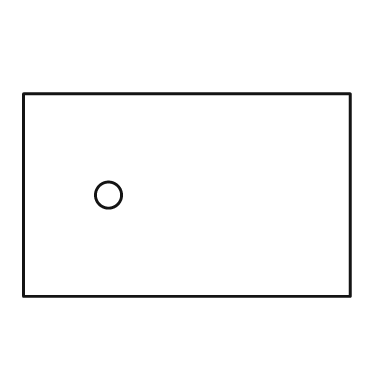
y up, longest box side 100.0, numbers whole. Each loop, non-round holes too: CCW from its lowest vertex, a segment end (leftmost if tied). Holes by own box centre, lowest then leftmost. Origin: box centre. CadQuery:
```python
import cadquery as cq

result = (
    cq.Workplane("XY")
    .moveTo(-50.0, -31.0)
    .lineTo(50.0, -31.0)
    .lineTo(50.0, 31.0)
    .lineTo(-50.0, 31.0)
    .close()
    .moveTo(-24.0, 0.0)
    .circle(4.0)
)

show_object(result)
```